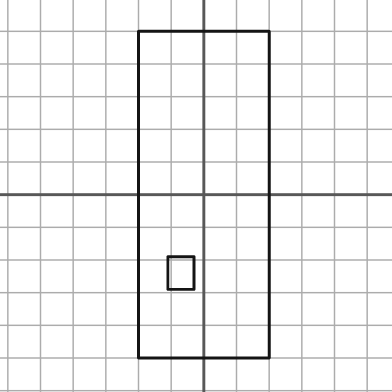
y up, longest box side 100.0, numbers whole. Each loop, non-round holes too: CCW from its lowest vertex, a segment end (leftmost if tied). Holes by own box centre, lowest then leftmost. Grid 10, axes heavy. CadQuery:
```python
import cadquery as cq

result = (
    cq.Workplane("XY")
    .moveTo(-20.0, -50.0)
    .lineTo(20.0, -50.0)
    .lineTo(20.0, 50.0)
    .lineTo(-20.0, 50.0)
    .close()
    .moveTo(-11.0, -29.0)
    .lineTo(-3.0, -29.0)
    .lineTo(-3.0, -19.0)
    .lineTo(-11.0, -19.0)
    .close()
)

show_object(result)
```